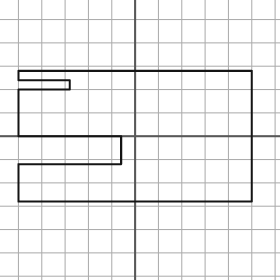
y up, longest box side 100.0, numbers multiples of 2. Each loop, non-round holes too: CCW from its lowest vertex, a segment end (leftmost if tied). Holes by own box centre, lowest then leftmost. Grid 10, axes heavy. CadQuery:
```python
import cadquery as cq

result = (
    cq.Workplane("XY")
    .moveTo(-50.0, -28.0)
    .lineTo(50.0, -28.0)
    .lineTo(50.0, 28.0)
    .lineTo(-50.0, 28.0)
    .lineTo(-50.0, 24.0)
    .lineTo(-28.0, 24.0)
    .lineTo(-28.0, 20.0)
    .lineTo(-50.0, 20.0)
    .lineTo(-50.0, 0.0)
    .lineTo(-6.0, 0.0)
    .lineTo(-6.0, -12.0)
    .lineTo(-50.0, -12.0)
    .close()
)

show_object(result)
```